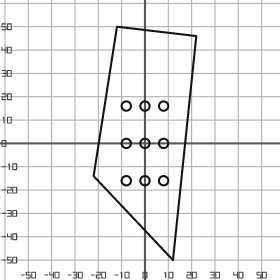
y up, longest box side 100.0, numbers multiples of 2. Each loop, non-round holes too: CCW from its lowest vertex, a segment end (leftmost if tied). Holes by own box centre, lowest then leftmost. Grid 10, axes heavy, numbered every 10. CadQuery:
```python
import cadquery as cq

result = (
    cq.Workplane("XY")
    .moveTo(12.0, -50.0)
    .lineTo(22.0, 46.0)
    .lineTo(-12.0, 50.0)
    .lineTo(-22.0, -14.0)
    .close()
    .moveTo(-8.0, -16.0)
    .circle(2.0)
    .moveTo(0.0, -16.0)
    .circle(2.0)
    .moveTo(8.0, -16.0)
    .circle(2.0)
    .moveTo(-8.0, 0.0)
    .circle(2.0)
    .moveTo(0.0, 0.0)
    .circle(2.0)
    .moveTo(8.0, 0.0)
    .circle(2.0)
    .moveTo(-8.0, 16.0)
    .circle(2.0)
    .moveTo(0.0, 16.0)
    .circle(2.0)
    .moveTo(8.0, 16.0)
    .circle(2.0)
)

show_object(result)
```